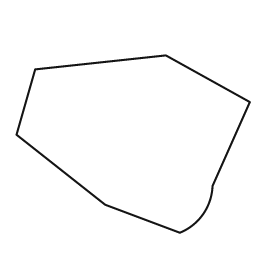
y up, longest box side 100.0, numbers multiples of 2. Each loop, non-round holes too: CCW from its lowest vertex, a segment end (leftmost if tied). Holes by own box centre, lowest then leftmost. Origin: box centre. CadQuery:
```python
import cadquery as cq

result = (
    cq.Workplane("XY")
    .moveTo(20.0, -38.0)
    .threePointArc((30.0, -30.0), (34.0, -18.0))
    .lineTo(50.0, 18.0)
    .lineTo(14.0, 38.0)
    .lineTo(-42.0, 32.0)
    .lineTo(-50.0, 4.0)
    .lineTo(-12.0, -26.0)
    .close()
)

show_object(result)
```